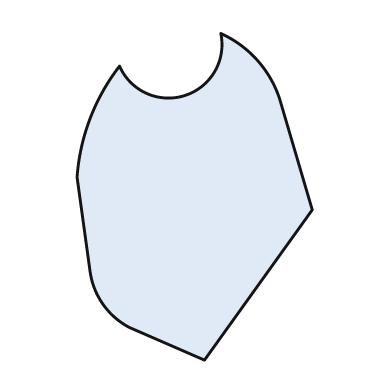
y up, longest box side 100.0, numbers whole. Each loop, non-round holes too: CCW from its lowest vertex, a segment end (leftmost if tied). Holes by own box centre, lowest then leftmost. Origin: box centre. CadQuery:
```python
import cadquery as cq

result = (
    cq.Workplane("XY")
    .moveTo(3.0, -50.0)
    .lineTo(36.0, -4.0)
    .lineTo(26.0, 30.0)
    .threePointArc((19.0, 42.0), (8.0, 50.0))
    .threePointArc((-3.0, 31.0), (-23.0, 40.0))
    .threePointArc((-32.0, 24.0), (-36.0, 6.0))
    .lineTo(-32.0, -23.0)
    .threePointArc((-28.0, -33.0), (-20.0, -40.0))
    .close()
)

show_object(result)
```